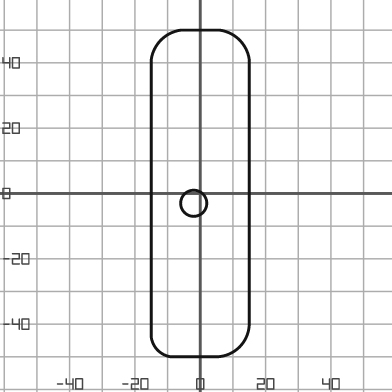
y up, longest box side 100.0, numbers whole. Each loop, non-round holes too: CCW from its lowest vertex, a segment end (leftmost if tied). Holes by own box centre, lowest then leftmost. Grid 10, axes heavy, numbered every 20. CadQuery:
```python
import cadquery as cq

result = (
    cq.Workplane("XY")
    .moveTo(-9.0, -50.0)
    .lineTo(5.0, -50.0)
    .threePointArc((12.0, -47.0), (15.0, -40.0))
    .lineTo(15.0, 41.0)
    .threePointArc((12.0, 47.0), (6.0, 50.0))
    .lineTo(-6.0, 50.0)
    .threePointArc((-12.0, 47.0), (-15.0, 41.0))
    .lineTo(-15.0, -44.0)
    .threePointArc((-13.0, -48.0), (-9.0, -50.0))
    .close()
    .moveTo(-2.0, -3.0)
    .circle(4.0)
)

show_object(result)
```